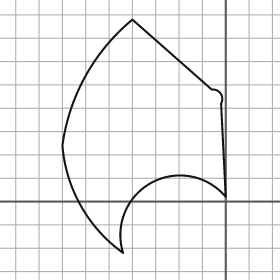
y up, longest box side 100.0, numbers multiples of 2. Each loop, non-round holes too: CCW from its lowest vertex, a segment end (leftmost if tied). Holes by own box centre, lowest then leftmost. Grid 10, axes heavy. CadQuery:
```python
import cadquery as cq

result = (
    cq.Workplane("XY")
    .moveTo(-44.0, -22.0)
    .threePointArc((-32.0, 8.0), (0.0, 2.0))
    .lineTo(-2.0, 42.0)
    .threePointArc((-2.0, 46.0), (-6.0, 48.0))
    .lineTo(-40.0, 78.0)
    .threePointArc((-60.0, 54.0), (-70.0, 24.0))
    .threePointArc((-62.0, -2.0), (-44.0, -22.0))
    .close()
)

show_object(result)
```